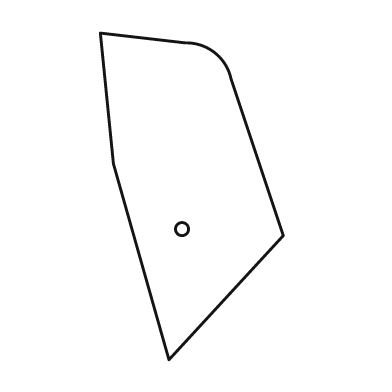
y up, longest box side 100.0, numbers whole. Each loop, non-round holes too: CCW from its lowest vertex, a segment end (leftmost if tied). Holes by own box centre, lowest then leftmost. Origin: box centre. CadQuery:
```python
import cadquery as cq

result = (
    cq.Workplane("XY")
    .moveTo(-7.0, -50.0)
    .lineTo(28.0, -12.0)
    .lineTo(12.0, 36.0)
    .threePointArc((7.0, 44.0), (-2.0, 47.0))
    .lineTo(-28.0, 50.0)
    .lineTo(-24.0, 10.0)
    .close()
    .moveTo(-3.0, -10.0)
    .circle(2.0)
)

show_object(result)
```